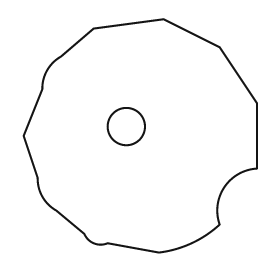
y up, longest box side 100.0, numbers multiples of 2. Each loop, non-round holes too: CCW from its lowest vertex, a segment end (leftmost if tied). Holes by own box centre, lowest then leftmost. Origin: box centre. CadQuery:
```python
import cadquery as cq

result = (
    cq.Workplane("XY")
    .moveTo(8.0, -50.0)
    .threePointArc((22.0, -46.0), (34.0, -38.0))
    .threePointArc((36.0, -22.0), (50.0, -14.0))
    .lineTo(50.0, 14.0)
    .lineTo(34.0, 38.0)
    .lineTo(10.0, 50.0)
    .lineTo(-20.0, 46.0)
    .lineTo(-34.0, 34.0)
    .threePointArc((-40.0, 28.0), (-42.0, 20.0))
    .lineTo(-50.0, 0.0)
    .lineTo(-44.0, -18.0)
    .threePointArc((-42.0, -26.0), (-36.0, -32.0))
    .lineTo(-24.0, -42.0)
    .threePointArc((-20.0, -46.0), (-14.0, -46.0))
    .close()
    .moveTo(-6.0, 4.0)
    .circle(8.0)
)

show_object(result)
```